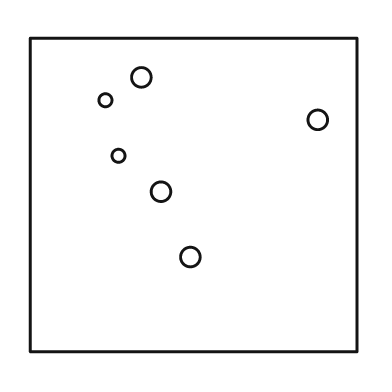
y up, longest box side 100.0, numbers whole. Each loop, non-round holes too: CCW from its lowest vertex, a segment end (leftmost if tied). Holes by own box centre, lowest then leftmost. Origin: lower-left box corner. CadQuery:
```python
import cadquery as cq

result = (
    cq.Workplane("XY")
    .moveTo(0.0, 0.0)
    .lineTo(100.0, 0.0)
    .lineTo(100.0, 96.0)
    .lineTo(0.0, 96.0)
    .close()
    .moveTo(49.0, 29.0)
    .circle(3.0)
    .moveTo(40.0, 49.0)
    .circle(3.0)
    .moveTo(27.0, 60.0)
    .circle(2.0)
    .moveTo(88.0, 71.0)
    .circle(3.0)
    .moveTo(23.0, 77.0)
    .circle(2.0)
    .moveTo(34.0, 84.0)
    .circle(3.0)
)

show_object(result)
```